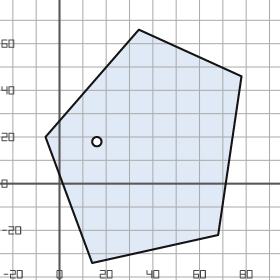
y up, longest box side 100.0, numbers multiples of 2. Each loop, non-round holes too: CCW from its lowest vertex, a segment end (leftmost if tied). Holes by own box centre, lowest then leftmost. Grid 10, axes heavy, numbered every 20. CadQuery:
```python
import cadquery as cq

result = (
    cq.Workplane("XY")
    .moveTo(14.0, -34.0)
    .lineTo(68.0, -22.0)
    .lineTo(78.0, 46.0)
    .lineTo(34.0, 66.0)
    .lineTo(-6.0, 20.0)
    .close()
    .moveTo(16.0, 18.0)
    .circle(2.0)
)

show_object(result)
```